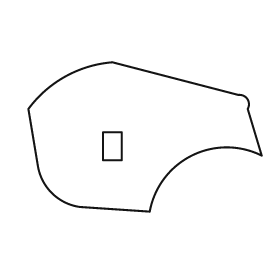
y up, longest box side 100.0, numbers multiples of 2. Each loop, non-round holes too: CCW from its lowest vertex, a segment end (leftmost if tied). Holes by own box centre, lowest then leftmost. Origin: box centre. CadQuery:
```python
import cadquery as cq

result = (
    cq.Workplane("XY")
    .moveTo(2.0, -32.0)
    .threePointArc((20.0, -8.0), (50.0, -8.0))
    .lineTo(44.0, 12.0)
    .threePointArc((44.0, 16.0), (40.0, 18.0))
    .lineTo(-14.0, 32.0)
    .threePointArc((-34.0, 26.0), (-50.0, 12.0))
    .lineTo(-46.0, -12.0)
    .threePointArc((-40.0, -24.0), (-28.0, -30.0))
    .close()
    .moveTo(-18.0, -10.0)
    .lineTo(-10.0, -10.0)
    .lineTo(-10.0, 2.0)
    .lineTo(-18.0, 2.0)
    .close()
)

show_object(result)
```